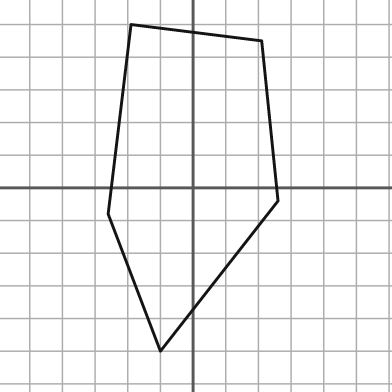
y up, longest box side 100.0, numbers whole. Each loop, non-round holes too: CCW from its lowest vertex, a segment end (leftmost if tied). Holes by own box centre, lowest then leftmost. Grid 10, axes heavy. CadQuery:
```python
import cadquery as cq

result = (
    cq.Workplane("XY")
    .moveTo(-10.0, -50.0)
    .lineTo(26.0, -4.0)
    .lineTo(21.0, 45.0)
    .lineTo(-19.0, 50.0)
    .lineTo(-26.0, -8.0)
    .close()
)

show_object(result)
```